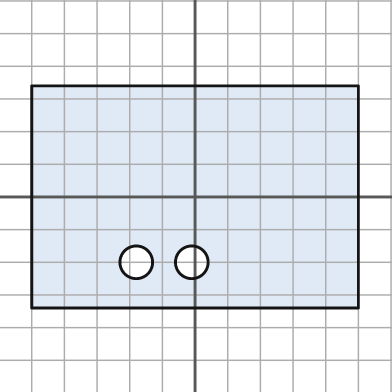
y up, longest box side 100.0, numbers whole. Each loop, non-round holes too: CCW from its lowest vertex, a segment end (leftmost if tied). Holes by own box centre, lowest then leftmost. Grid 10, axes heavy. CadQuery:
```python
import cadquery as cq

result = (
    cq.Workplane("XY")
    .moveTo(-50.0, -34.0)
    .lineTo(50.0, -34.0)
    .lineTo(50.0, 34.0)
    .lineTo(-50.0, 34.0)
    .close()
    .moveTo(-18.0, -20.0)
    .circle(5.0)
    .moveTo(-1.0, -20.0)
    .circle(5.0)
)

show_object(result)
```